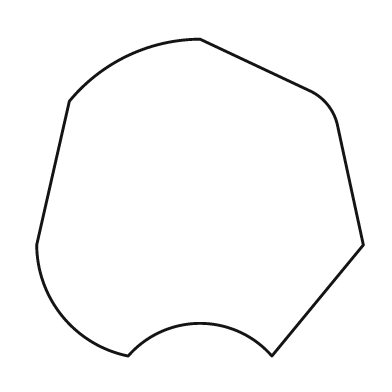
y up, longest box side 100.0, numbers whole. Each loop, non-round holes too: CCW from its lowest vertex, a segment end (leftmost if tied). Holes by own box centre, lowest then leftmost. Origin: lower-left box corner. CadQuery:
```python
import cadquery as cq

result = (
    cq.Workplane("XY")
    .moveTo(28.0, 0.0)
    .threePointArc((50.0, 10.0), (72.0, 0.0))
    .lineTo(100.0, 34.0)
    .lineTo(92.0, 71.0)
    .threePointArc((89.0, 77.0), (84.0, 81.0))
    .lineTo(50.0, 97.0)
    .threePointArc((28.0, 92.0), (10.0, 78.0))
    .lineTo(0.0, 34.0)
    .threePointArc((8.0, 12.0), (28.0, 0.0))
    .close()
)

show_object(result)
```